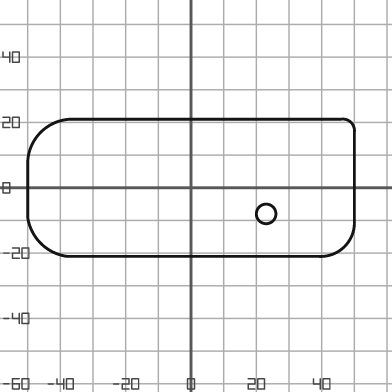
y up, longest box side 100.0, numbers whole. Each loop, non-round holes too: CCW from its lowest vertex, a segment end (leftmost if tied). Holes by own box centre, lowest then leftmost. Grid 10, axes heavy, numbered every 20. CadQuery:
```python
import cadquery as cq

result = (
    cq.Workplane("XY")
    .moveTo(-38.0, -21.0)
    .lineTo(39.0, -21.0)
    .threePointArc((47.0, -18.0), (50.0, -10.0))
    .lineTo(50.0, 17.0)
    .threePointArc((49.0, 20.0), (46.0, 21.0))
    .lineTo(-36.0, 21.0)
    .threePointArc((-46.0, 17.0), (-50.0, 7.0))
    .lineTo(-50.0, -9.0)
    .threePointArc((-46.0, -17.0), (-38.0, -21.0))
    .close()
    .moveTo(23.0, -8.0)
    .circle(3.0)
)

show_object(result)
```